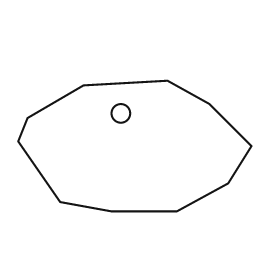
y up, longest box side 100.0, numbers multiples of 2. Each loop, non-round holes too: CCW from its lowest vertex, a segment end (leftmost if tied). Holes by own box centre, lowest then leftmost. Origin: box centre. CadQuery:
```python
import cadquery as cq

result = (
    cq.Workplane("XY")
    .moveTo(-10.0, -28.0)
    .lineTo(18.0, -28.0)
    .lineTo(40.0, -16.0)
    .lineTo(50.0, 0.0)
    .lineTo(32.0, 18.0)
    .lineTo(14.0, 28.0)
    .lineTo(-22.0, 26.0)
    .lineTo(-46.0, 12.0)
    .lineTo(-50.0, 2.0)
    .lineTo(-32.0, -24.0)
    .close()
    .moveTo(-6.0, 14.0)
    .circle(4.0)
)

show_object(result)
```